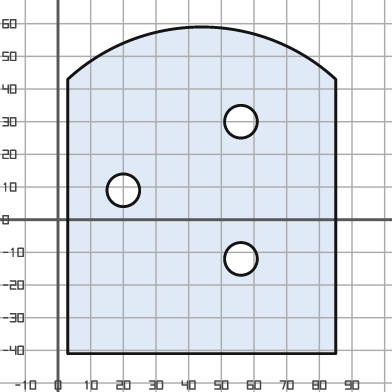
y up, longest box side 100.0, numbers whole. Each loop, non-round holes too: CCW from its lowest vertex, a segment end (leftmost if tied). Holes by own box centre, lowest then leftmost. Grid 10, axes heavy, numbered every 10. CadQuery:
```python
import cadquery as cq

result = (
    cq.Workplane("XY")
    .moveTo(3.0, -41.0)
    .lineTo(85.0, -41.0)
    .lineTo(85.0, 43.0)
    .threePointArc((44.0, 59.0), (3.0, 43.0))
    .close()
    .moveTo(56.0, -12.0)
    .circle(5.0)
    .moveTo(20.0, 9.0)
    .circle(5.0)
    .moveTo(56.0, 30.0)
    .circle(5.0)
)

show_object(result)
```